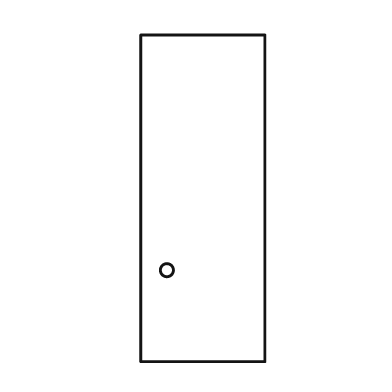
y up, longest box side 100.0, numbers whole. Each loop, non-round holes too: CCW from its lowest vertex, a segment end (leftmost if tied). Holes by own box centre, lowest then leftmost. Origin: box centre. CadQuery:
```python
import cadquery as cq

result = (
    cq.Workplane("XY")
    .moveTo(-19.0, -50.0)
    .lineTo(19.0, -50.0)
    .lineTo(19.0, 50.0)
    .lineTo(-19.0, 50.0)
    .close()
    .moveTo(-11.0, -22.0)
    .circle(2.0)
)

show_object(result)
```